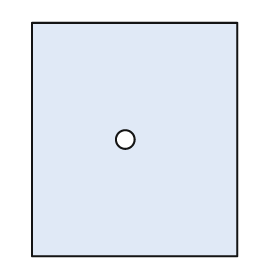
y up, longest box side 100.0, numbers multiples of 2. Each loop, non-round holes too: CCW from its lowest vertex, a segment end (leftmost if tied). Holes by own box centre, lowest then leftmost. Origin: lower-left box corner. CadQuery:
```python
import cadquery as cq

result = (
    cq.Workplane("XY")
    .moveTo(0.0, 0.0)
    .lineTo(88.0, 0.0)
    .lineTo(88.0, 100.0)
    .lineTo(0.0, 100.0)
    .close()
    .moveTo(40.0, 50.0)
    .circle(4.0)
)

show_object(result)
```